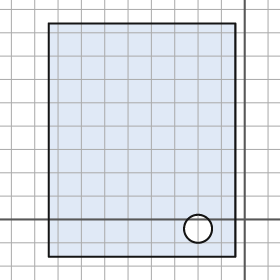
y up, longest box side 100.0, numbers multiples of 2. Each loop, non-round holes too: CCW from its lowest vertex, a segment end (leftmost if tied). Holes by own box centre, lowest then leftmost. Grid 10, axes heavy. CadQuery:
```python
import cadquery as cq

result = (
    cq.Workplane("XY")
    .moveTo(-84.0, -16.0)
    .lineTo(-4.0, -16.0)
    .lineTo(-4.0, 84.0)
    .lineTo(-84.0, 84.0)
    .close()
    .moveTo(-20.0, -4.0)
    .circle(6.0)
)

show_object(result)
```